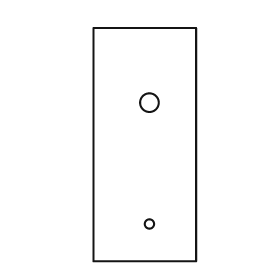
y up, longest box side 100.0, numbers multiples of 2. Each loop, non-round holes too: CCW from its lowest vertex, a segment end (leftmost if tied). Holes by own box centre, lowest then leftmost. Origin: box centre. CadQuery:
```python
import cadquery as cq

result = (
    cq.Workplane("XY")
    .moveTo(-22.0, -50.0)
    .lineTo(22.0, -50.0)
    .lineTo(22.0, 50.0)
    .lineTo(-22.0, 50.0)
    .close()
    .moveTo(2.0, -34.0)
    .circle(2.0)
    .moveTo(2.0, 18.0)
    .circle(4.0)
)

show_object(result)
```